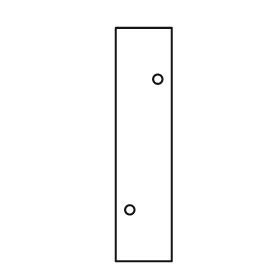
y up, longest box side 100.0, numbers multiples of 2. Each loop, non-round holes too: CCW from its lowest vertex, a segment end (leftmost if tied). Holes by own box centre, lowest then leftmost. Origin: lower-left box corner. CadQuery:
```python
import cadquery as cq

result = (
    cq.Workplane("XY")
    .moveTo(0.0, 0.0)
    .lineTo(24.0, 0.0)
    .lineTo(24.0, 100.0)
    .lineTo(0.0, 100.0)
    .close()
    .moveTo(6.0, 22.0)
    .circle(2.0)
    .moveTo(18.0, 78.0)
    .circle(2.0)
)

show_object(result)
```